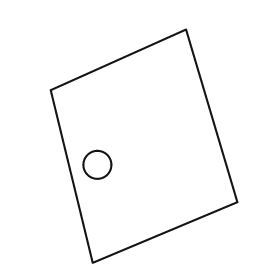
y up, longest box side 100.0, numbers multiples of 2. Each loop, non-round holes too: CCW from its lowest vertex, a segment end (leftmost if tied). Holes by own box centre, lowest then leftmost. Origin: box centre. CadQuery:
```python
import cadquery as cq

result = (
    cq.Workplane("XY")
    .moveTo(-22.0, -50.0)
    .lineTo(40.0, -24.0)
    .lineTo(18.0, 50.0)
    .lineTo(-40.0, 24.0)
    .close()
    .moveTo(-20.0, -8.0)
    .circle(6.0)
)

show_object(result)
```